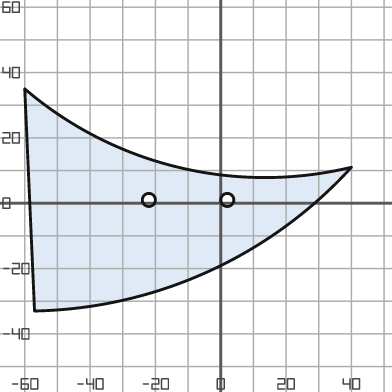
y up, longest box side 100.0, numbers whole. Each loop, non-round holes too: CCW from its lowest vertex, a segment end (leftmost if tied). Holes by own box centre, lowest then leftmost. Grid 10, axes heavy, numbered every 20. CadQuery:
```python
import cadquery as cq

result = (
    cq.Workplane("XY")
    .moveTo(-57.0, -33.0)
    .threePointArc((-4.0, -21.0), (40.0, 11.0))
    .threePointArc((-13.0, 11.0), (-60.0, 35.0))
    .close()
    .moveTo(-22.0, 1.0)
    .circle(2.0)
    .moveTo(2.0, 1.0)
    .circle(2.0)
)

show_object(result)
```